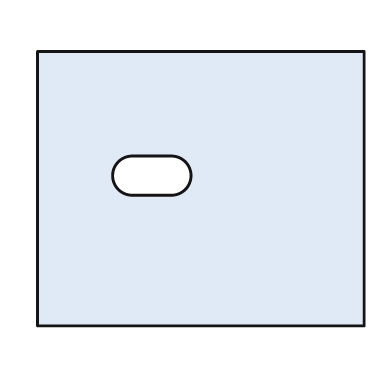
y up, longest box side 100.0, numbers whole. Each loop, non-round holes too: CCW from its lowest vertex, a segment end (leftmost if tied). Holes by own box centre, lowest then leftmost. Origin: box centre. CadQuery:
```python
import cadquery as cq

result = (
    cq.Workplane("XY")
    .moveTo(-50.0, -42.0)
    .lineTo(50.0, -42.0)
    .lineTo(50.0, 42.0)
    .lineTo(-50.0, 42.0)
    .close()
    .moveTo(-21.0, -2.0)
    .lineTo(-9.0, -2.0)
    .threePointArc((-3.0, 4.0), (-9.0, 10.0))
    .lineTo(-21.0, 10.0)
    .threePointArc((-27.0, 4.0), (-21.0, -2.0))
    .close()
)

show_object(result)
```